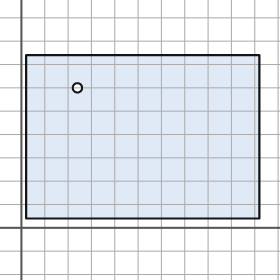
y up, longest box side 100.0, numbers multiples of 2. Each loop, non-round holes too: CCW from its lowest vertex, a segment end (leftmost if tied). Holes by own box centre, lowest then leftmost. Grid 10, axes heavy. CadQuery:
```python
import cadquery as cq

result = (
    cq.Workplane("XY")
    .moveTo(2.0, 4.0)
    .lineTo(102.0, 4.0)
    .lineTo(102.0, 74.0)
    .lineTo(2.0, 74.0)
    .close()
    .moveTo(24.0, 60.0)
    .circle(2.0)
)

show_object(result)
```